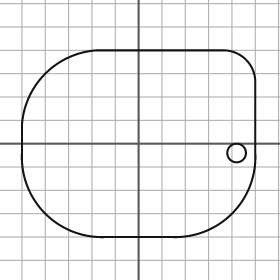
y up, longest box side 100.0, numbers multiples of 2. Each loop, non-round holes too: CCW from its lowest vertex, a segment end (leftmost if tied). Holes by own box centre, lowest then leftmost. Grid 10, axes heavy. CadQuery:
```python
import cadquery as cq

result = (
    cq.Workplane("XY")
    .moveTo(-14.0, -40.0)
    .lineTo(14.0, -40.0)
    .threePointArc((40.0, -30.0), (50.0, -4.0))
    .lineTo(50.0, 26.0)
    .threePointArc((46.0, 36.0), (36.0, 40.0))
    .lineTo(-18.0, 40.0)
    .threePointArc((-40.0, 30.0), (-50.0, 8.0))
    .lineTo(-50.0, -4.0)
    .threePointArc((-40.0, -30.0), (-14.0, -40.0))
    .close()
    .moveTo(42.0, -4.0)
    .circle(4.0)
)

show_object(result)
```